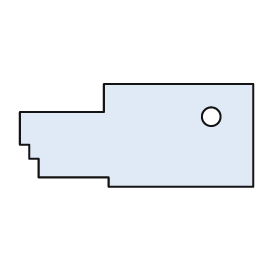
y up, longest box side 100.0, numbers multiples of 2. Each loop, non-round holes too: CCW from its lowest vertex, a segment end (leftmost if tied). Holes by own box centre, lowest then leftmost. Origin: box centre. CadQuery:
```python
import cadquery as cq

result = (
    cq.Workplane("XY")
    .moveTo(-12.0, -22.0)
    .lineTo(50.0, -22.0)
    .lineTo(50.0, 22.0)
    .lineTo(-14.0, 22.0)
    .lineTo(-14.0, 10.0)
    .lineTo(-50.0, 10.0)
    .lineTo(-50.0, -4.0)
    .lineTo(-46.0, -4.0)
    .lineTo(-46.0, -10.0)
    .lineTo(-42.0, -10.0)
    .lineTo(-42.0, -18.0)
    .lineTo(-12.0, -18.0)
    .close()
    .moveTo(32.0, 8.0)
    .circle(4.0)
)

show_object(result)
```